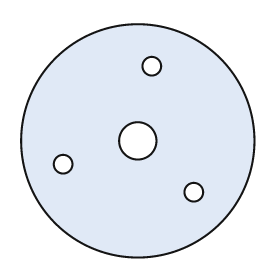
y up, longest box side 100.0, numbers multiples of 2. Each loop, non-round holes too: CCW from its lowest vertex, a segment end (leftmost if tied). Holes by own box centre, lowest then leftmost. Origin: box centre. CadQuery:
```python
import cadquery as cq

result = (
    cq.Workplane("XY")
    .moveTo(0.0, 0.0)
    .circle(50.0)
    .moveTo(24.0, -22.0)
    .circle(4.0)
    .moveTo(-32.0, -10.0)
    .circle(4.0)
    .moveTo(0.0, 0.0)
    .circle(8.0)
    .moveTo(6.0, 32.0)
    .circle(4.0)
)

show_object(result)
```